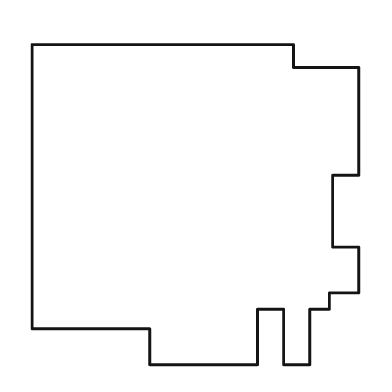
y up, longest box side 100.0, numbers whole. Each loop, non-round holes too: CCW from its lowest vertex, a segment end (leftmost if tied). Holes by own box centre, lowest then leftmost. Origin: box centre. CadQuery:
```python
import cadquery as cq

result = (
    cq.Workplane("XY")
    .moveTo(-14.0, -49.0)
    .lineTo(19.0, -49.0)
    .lineTo(19.0, -32.0)
    .lineTo(27.0, -32.0)
    .lineTo(27.0, -49.0)
    .lineTo(35.0, -49.0)
    .lineTo(35.0, -32.0)
    .lineTo(41.0, -32.0)
    .lineTo(41.0, -27.0)
    .lineTo(50.0, -27.0)
    .lineTo(50.0, -13.0)
    .lineTo(42.0, -13.0)
    .lineTo(42.0, 9.0)
    .lineTo(50.0, 9.0)
    .lineTo(50.0, 42.0)
    .lineTo(30.0, 42.0)
    .lineTo(30.0, 49.0)
    .lineTo(-50.0, 49.0)
    .lineTo(-50.0, -38.0)
    .lineTo(-14.0, -38.0)
    .close()
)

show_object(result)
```